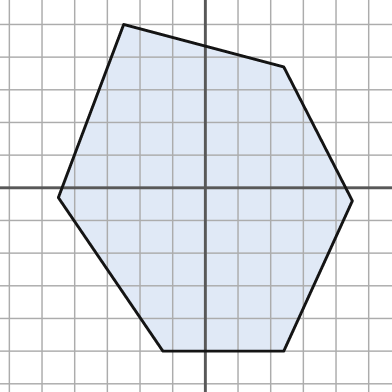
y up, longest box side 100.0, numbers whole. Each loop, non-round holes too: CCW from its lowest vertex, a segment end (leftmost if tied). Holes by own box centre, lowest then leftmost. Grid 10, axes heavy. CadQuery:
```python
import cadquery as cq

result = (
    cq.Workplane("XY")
    .moveTo(-13.0, -50.0)
    .lineTo(24.0, -50.0)
    .lineTo(45.0, -4.0)
    .lineTo(24.0, 37.0)
    .lineTo(-25.0, 50.0)
    .lineTo(-45.0, -3.0)
    .close()
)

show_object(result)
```